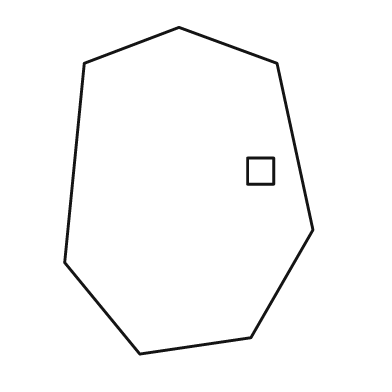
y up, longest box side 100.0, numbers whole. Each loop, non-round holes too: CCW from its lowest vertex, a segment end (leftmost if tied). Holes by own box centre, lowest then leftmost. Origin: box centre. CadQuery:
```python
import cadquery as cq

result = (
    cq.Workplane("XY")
    .moveTo(-15.0, -50.0)
    .lineTo(19.0, -45.0)
    .lineTo(38.0, -12.0)
    .lineTo(27.0, 39.0)
    .lineTo(-3.0, 50.0)
    .lineTo(-32.0, 39.0)
    .lineTo(-38.0, -22.0)
    .close()
    .moveTo(18.0, 2.0)
    .lineTo(26.0, 2.0)
    .lineTo(26.0, 10.0)
    .lineTo(18.0, 10.0)
    .close()
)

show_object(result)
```